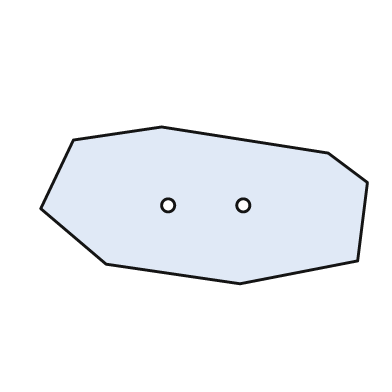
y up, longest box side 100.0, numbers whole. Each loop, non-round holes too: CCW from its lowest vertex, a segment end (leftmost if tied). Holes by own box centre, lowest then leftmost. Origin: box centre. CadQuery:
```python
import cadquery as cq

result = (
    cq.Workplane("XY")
    .moveTo(11.0, -24.0)
    .lineTo(47.0, -17.0)
    .lineTo(50.0, 7.0)
    .lineTo(38.0, 16.0)
    .lineTo(-13.0, 24.0)
    .lineTo(-40.0, 20.0)
    .lineTo(-50.0, -1.0)
    .lineTo(-30.0, -18.0)
    .close()
    .moveTo(-11.0, 0.0)
    .circle(2.0)
    .moveTo(12.0, 0.0)
    .circle(2.0)
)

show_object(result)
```